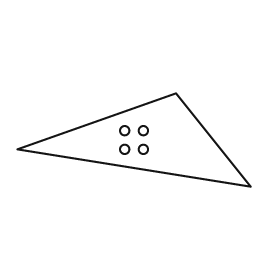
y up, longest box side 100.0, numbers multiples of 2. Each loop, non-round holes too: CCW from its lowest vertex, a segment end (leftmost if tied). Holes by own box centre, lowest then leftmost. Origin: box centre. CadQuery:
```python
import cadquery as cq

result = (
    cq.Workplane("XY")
    .moveTo(50.0, -20.0)
    .lineTo(18.0, 20.0)
    .lineTo(-50.0, -4.0)
    .close()
    .moveTo(-4.0, -4.0)
    .circle(2.0)
    .moveTo(4.0, -4.0)
    .circle(2.0)
    .moveTo(-4.0, 4.0)
    .circle(2.0)
    .moveTo(4.0, 4.0)
    .circle(2.0)
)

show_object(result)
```